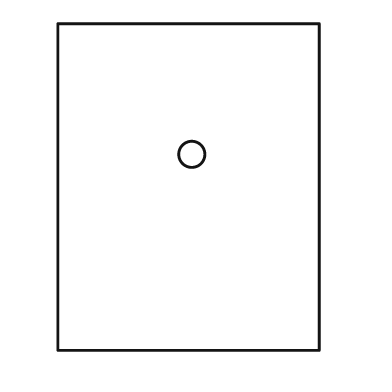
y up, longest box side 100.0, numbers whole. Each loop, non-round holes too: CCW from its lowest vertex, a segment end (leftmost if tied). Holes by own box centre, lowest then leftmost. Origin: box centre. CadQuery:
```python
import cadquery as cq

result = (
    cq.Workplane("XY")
    .moveTo(-40.0, -50.0)
    .lineTo(40.0, -50.0)
    .lineTo(40.0, 50.0)
    .lineTo(-40.0, 50.0)
    .close()
    .moveTo(1.0, 10.0)
    .circle(4.0)
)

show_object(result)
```